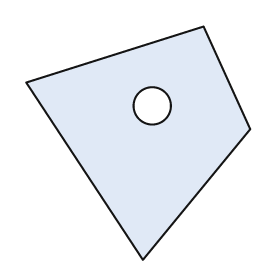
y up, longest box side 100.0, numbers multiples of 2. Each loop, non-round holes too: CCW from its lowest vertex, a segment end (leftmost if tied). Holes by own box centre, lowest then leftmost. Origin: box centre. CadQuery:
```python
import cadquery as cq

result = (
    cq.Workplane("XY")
    .moveTo(2.0, -50.0)
    .lineTo(48.0, 6.0)
    .lineTo(28.0, 50.0)
    .lineTo(-48.0, 26.0)
    .close()
    .moveTo(6.0, 16.0)
    .circle(8.0)
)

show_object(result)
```